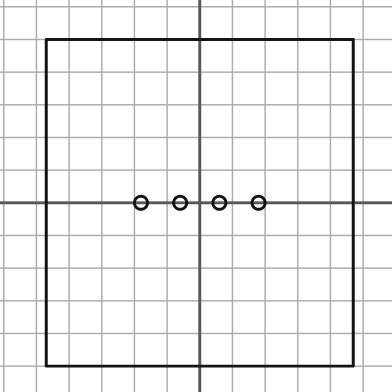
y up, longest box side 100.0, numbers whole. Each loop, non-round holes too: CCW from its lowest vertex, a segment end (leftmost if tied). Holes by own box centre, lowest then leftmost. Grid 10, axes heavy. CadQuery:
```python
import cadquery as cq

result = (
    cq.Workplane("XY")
    .moveTo(-47.0, -50.0)
    .lineTo(47.0, -50.0)
    .lineTo(47.0, 50.0)
    .lineTo(-47.0, 50.0)
    .close()
    .moveTo(-18.0, 0.0)
    .circle(2.0)
    .moveTo(-6.0, 0.0)
    .circle(2.0)
    .moveTo(6.0, 0.0)
    .circle(2.0)
    .moveTo(18.0, 0.0)
    .circle(2.0)
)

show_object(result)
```